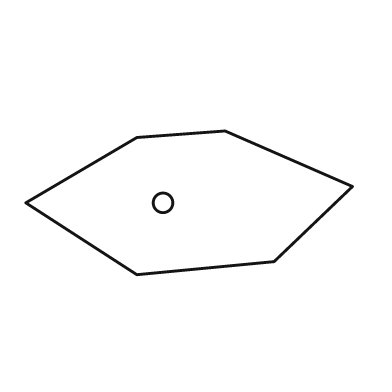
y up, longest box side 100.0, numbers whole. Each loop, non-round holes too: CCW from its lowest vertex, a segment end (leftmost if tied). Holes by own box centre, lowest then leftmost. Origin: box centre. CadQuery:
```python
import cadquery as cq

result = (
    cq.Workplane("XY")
    .moveTo(-16.0, -22.0)
    .lineTo(26.0, -18.0)
    .lineTo(50.0, 5.0)
    .lineTo(11.0, 22.0)
    .lineTo(-16.0, 20.0)
    .lineTo(-50.0, 0.0)
    .close()
    .moveTo(-8.0, 0.0)
    .circle(3.0)
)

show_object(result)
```